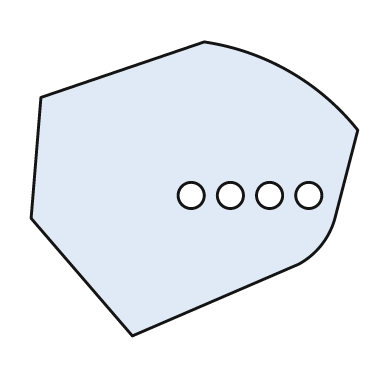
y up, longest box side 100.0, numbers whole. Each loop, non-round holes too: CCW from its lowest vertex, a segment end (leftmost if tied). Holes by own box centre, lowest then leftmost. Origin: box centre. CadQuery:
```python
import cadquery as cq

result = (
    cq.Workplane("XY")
    .moveTo(-19.0, -45.0)
    .lineTo(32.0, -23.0)
    .threePointArc((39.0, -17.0), (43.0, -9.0))
    .lineTo(50.0, 18.0)
    .threePointArc((29.0, 36.0), (3.0, 45.0))
    .lineTo(-47.0, 28.0)
    .lineTo(-50.0, -9.0)
    .close()
    .moveTo(-1.0, -2.0)
    .circle(4.0)
    .moveTo(11.0, -2.0)
    .circle(4.0)
    .moveTo(23.0, -2.0)
    .circle(4.0)
    .moveTo(35.0, -2.0)
    .circle(4.0)
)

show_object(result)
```